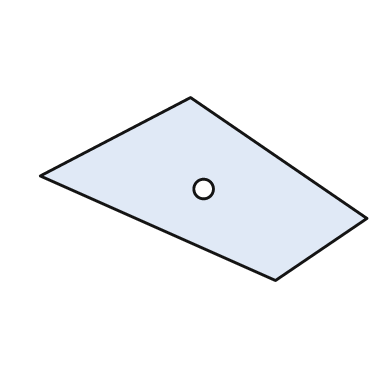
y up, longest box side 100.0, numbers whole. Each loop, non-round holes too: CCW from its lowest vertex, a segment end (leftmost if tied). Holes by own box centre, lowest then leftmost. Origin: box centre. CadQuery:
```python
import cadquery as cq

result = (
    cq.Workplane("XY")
    .moveTo(22.0, -28.0)
    .lineTo(50.0, -9.0)
    .lineTo(-4.0, 28.0)
    .lineTo(-50.0, 4.0)
    .close()
    .moveTo(0.0, 0.0)
    .circle(3.0)
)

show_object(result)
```